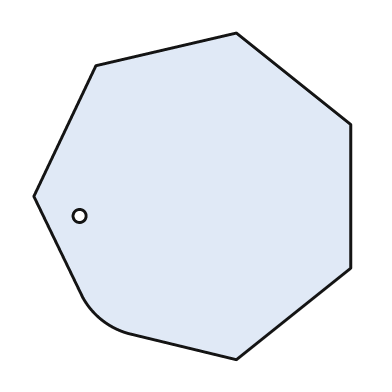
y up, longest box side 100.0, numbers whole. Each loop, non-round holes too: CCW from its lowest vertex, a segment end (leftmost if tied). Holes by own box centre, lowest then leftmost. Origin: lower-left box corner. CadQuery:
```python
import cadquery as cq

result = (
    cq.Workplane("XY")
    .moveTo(62.0, 0.0)
    .lineTo(97.0, 28.0)
    .lineTo(97.0, 72.0)
    .lineTo(62.0, 100.0)
    .lineTo(19.0, 90.0)
    .lineTo(0.0, 50.0)
    .lineTo(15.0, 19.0)
    .threePointArc((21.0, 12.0), (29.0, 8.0))
    .close()
    .moveTo(14.0, 44.0)
    .circle(2.0)
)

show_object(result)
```